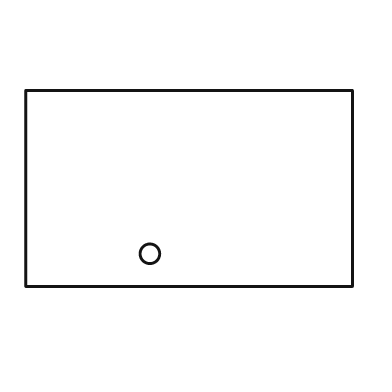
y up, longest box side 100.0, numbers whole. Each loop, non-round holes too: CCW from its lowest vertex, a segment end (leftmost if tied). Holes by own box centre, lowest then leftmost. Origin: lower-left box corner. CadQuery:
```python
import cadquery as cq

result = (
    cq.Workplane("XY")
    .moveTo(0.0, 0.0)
    .lineTo(100.0, 0.0)
    .lineTo(100.0, 60.0)
    .lineTo(0.0, 60.0)
    .close()
    .moveTo(38.0, 10.0)
    .circle(3.0)
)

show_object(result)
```